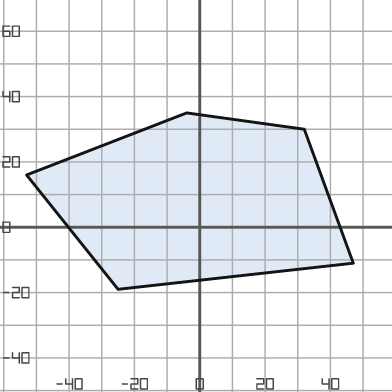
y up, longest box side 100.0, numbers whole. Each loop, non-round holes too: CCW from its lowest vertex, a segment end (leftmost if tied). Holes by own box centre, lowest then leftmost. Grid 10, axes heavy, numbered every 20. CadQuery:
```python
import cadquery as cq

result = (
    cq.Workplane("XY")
    .moveTo(-25.0, -19.0)
    .lineTo(47.0, -11.0)
    .lineTo(32.0, 30.0)
    .lineTo(-4.0, 35.0)
    .lineTo(-53.0, 16.0)
    .close()
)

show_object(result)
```